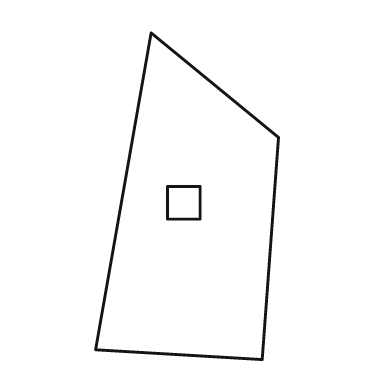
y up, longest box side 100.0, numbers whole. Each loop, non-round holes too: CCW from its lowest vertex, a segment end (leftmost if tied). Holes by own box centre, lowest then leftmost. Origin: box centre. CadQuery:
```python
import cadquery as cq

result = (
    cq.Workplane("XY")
    .moveTo(23.0, -50.0)
    .lineTo(28.0, 18.0)
    .lineTo(-11.0, 50.0)
    .lineTo(-28.0, -47.0)
    .close()
    .moveTo(-6.0, -7.0)
    .lineTo(4.0, -7.0)
    .lineTo(4.0, 3.0)
    .lineTo(-6.0, 3.0)
    .close()
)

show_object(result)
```